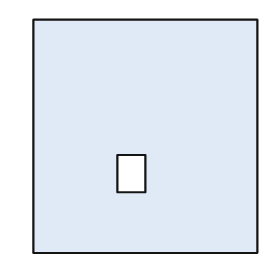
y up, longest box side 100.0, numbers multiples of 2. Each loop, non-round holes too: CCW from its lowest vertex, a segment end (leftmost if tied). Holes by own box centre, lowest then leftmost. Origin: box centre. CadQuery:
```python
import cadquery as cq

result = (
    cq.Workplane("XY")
    .moveTo(-48.0, -50.0)
    .lineTo(48.0, -50.0)
    .lineTo(48.0, 50.0)
    .lineTo(-48.0, 50.0)
    .close()
    .moveTo(-12.0, -24.0)
    .lineTo(0.0, -24.0)
    .lineTo(0.0, -8.0)
    .lineTo(-12.0, -8.0)
    .close()
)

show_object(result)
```